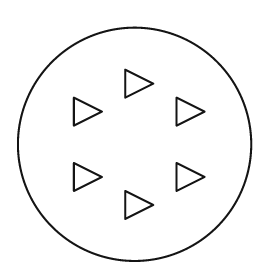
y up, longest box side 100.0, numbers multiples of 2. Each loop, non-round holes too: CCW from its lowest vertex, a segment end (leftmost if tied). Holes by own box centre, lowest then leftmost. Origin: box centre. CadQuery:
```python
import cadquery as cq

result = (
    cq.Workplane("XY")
    .moveTo(0.0, 0.0)
    .circle(50.0)
    .moveTo(-4.0, -32.0)
    .lineTo(8.0, -26.0)
    .lineTo(-4.0, -20.0)
    .close()
    .moveTo(-26.0, -20.0)
    .lineTo(-14.0, -14.0)
    .lineTo(-26.0, -8.0)
    .close()
    .moveTo(18.0, -20.0)
    .lineTo(30.0, -14.0)
    .lineTo(18.0, -8.0)
    .close()
    .moveTo(-26.0, 8.0)
    .lineTo(-14.0, 14.0)
    .lineTo(-26.0, 20.0)
    .close()
    .moveTo(18.0, 8.0)
    .lineTo(30.0, 14.0)
    .lineTo(18.0, 20.0)
    .close()
    .moveTo(-4.0, 20.0)
    .lineTo(8.0, 26.0)
    .lineTo(-4.0, 32.0)
    .close()
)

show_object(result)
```